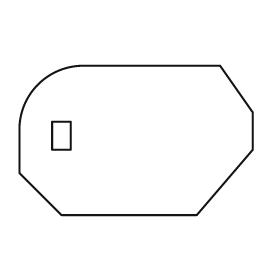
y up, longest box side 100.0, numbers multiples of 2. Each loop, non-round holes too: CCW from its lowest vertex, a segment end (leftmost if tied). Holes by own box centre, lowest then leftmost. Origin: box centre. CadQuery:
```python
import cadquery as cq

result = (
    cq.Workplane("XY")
    .moveTo(-32.0, -32.0)
    .lineTo(26.0, -32.0)
    .lineTo(50.0, -4.0)
    .lineTo(50.0, 12.0)
    .lineTo(36.0, 32.0)
    .lineTo(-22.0, 32.0)
    .threePointArc((-42.0, 24.0), (-50.0, 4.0))
    .lineTo(-50.0, -14.0)
    .close()
    .moveTo(-36.0, -4.0)
    .lineTo(-28.0, -4.0)
    .lineTo(-28.0, 8.0)
    .lineTo(-36.0, 8.0)
    .close()
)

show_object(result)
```